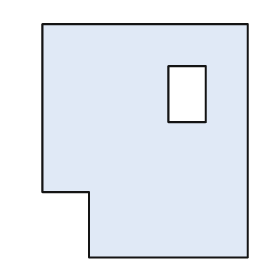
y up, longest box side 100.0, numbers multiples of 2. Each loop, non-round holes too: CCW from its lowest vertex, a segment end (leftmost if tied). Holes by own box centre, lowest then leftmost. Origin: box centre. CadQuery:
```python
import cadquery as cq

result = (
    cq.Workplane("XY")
    .moveTo(-24.0, -50.0)
    .lineTo(44.0, -50.0)
    .lineTo(44.0, 50.0)
    .lineTo(-44.0, 50.0)
    .lineTo(-44.0, -22.0)
    .lineTo(-24.0, -22.0)
    .close()
    .moveTo(10.0, 8.0)
    .lineTo(26.0, 8.0)
    .lineTo(26.0, 32.0)
    .lineTo(10.0, 32.0)
    .close()
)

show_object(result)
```